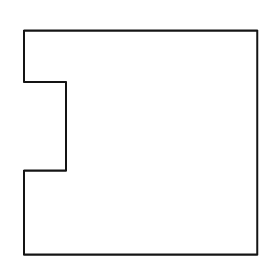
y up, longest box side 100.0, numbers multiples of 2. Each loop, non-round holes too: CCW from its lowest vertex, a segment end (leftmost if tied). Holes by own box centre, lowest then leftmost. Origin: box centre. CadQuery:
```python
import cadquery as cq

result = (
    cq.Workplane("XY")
    .moveTo(-50.0, -48.0)
    .lineTo(50.0, -48.0)
    .lineTo(50.0, 48.0)
    .lineTo(-50.0, 48.0)
    .lineTo(-50.0, 26.0)
    .lineTo(-32.0, 26.0)
    .lineTo(-32.0, -12.0)
    .lineTo(-50.0, -12.0)
    .close()
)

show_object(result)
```